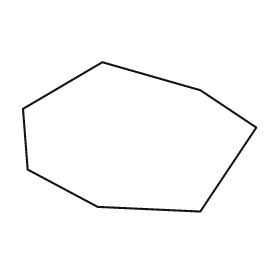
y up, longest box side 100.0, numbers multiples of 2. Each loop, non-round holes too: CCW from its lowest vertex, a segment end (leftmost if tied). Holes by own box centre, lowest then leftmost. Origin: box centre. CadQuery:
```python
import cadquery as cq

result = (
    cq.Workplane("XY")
    .moveTo(26.0, -32.0)
    .lineTo(50.0, 4.0)
    .lineTo(26.0, 20.0)
    .lineTo(-16.0, 32.0)
    .lineTo(-50.0, 12.0)
    .lineTo(-48.0, -14.0)
    .lineTo(-18.0, -30.0)
    .close()
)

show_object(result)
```